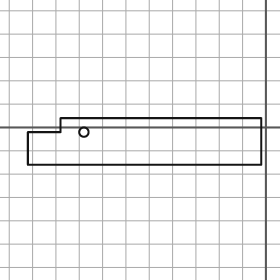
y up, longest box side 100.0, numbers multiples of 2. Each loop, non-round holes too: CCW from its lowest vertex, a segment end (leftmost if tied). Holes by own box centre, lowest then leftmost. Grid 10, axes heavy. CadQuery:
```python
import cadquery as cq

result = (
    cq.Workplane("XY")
    .moveTo(-102.0, -16.0)
    .lineTo(-2.0, -16.0)
    .lineTo(-2.0, 4.0)
    .lineTo(-88.0, 4.0)
    .lineTo(-88.0, -2.0)
    .lineTo(-102.0, -2.0)
    .close()
    .moveTo(-78.0, -2.0)
    .circle(2.0)
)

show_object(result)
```